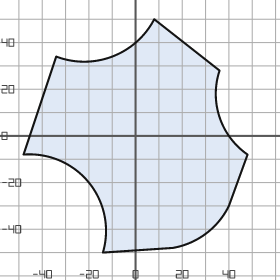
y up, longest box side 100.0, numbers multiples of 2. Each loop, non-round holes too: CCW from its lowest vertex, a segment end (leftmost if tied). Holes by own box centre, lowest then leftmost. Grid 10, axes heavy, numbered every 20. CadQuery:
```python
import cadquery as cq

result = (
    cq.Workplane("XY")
    .moveTo(-14.0, -50.0)
    .lineTo(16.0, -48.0)
    .threePointArc((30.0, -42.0), (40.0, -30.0))
    .lineTo(48.0, -8.0)
    .threePointArc((36.0, 8.0), (36.0, 28.0))
    .lineTo(8.0, 50.0)
    .threePointArc((-10.0, 34.0), (-34.0, 34.0))
    .lineTo(-48.0, -8.0)
    .threePointArc((-20.0, -20.0), (-14.0, -50.0))
    .close()
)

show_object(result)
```